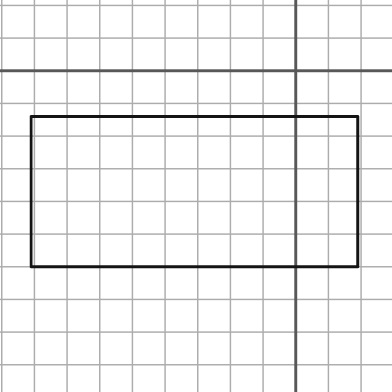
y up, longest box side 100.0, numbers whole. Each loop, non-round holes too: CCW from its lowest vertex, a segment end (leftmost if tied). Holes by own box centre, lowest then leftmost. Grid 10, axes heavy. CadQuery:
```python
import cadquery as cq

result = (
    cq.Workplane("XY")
    .moveTo(-81.0, -60.0)
    .lineTo(19.0, -60.0)
    .lineTo(19.0, -14.0)
    .lineTo(-81.0, -14.0)
    .close()
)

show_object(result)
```